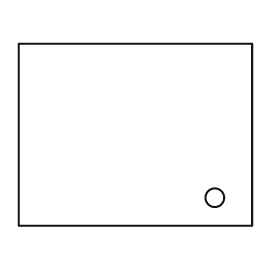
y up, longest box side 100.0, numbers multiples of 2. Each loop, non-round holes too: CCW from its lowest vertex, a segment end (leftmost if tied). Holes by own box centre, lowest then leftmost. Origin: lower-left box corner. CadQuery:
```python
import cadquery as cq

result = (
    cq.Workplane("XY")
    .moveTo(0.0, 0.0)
    .lineTo(100.0, 0.0)
    .lineTo(100.0, 78.0)
    .lineTo(0.0, 78.0)
    .close()
    .moveTo(84.0, 12.0)
    .circle(4.0)
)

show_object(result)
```